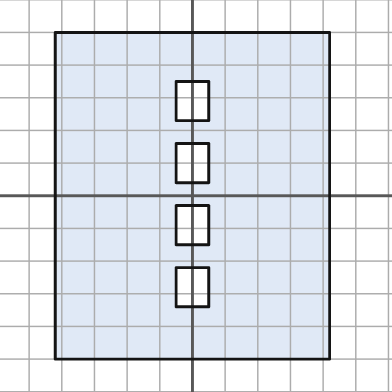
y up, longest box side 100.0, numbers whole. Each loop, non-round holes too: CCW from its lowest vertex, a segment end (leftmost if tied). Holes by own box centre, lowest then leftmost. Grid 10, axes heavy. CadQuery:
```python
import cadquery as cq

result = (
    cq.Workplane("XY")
    .moveTo(-42.0, -50.0)
    .lineTo(42.0, -50.0)
    .lineTo(42.0, 50.0)
    .lineTo(-42.0, 50.0)
    .close()
    .moveTo(-5.0, -34.0)
    .lineTo(5.0, -34.0)
    .lineTo(5.0, -22.0)
    .lineTo(-5.0, -22.0)
    .close()
    .moveTo(-5.0, -15.0)
    .lineTo(5.0, -15.0)
    .lineTo(5.0, -3.0)
    .lineTo(-5.0, -3.0)
    .close()
    .moveTo(-5.0, 4.0)
    .lineTo(5.0, 4.0)
    .lineTo(5.0, 16.0)
    .lineTo(-5.0, 16.0)
    .close()
    .moveTo(-5.0, 23.0)
    .lineTo(5.0, 23.0)
    .lineTo(5.0, 35.0)
    .lineTo(-5.0, 35.0)
    .close()
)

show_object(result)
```